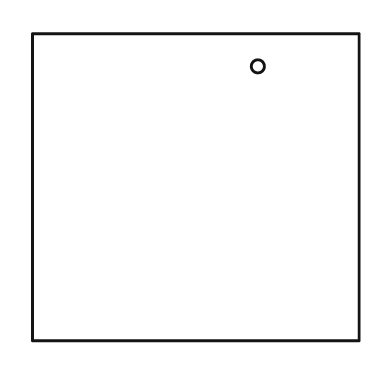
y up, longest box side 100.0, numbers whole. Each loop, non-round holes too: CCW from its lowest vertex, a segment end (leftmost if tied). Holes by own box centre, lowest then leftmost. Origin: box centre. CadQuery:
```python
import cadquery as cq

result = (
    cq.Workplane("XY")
    .moveTo(-50.0, -47.0)
    .lineTo(50.0, -47.0)
    .lineTo(50.0, 47.0)
    .lineTo(-50.0, 47.0)
    .close()
    .moveTo(19.0, 37.0)
    .circle(2.0)
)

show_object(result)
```